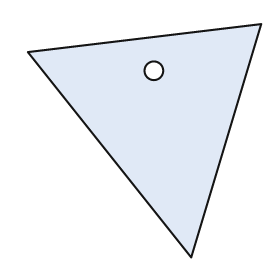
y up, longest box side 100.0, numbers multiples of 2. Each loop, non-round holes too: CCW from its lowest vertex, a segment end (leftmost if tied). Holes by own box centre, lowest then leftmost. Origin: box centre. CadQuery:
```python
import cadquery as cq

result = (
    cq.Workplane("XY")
    .moveTo(20.0, -50.0)
    .lineTo(50.0, 50.0)
    .lineTo(-50.0, 38.0)
    .close()
    .moveTo(4.0, 30.0)
    .circle(4.0)
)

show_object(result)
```